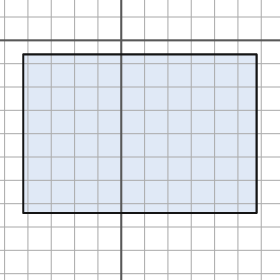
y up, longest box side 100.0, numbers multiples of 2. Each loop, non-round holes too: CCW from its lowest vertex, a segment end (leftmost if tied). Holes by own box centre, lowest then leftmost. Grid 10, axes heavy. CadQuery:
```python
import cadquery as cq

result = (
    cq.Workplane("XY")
    .moveTo(-42.0, -74.0)
    .lineTo(58.0, -74.0)
    .lineTo(58.0, -6.0)
    .lineTo(-42.0, -6.0)
    .close()
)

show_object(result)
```